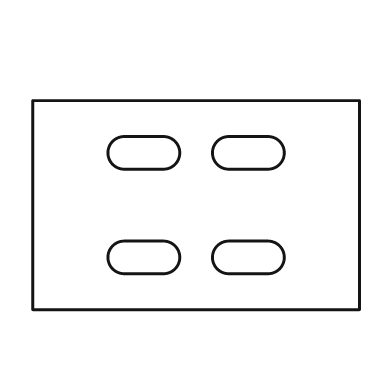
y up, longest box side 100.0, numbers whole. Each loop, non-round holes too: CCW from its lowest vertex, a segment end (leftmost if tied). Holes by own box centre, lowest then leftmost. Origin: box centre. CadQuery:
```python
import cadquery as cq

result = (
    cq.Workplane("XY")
    .moveTo(-50.0, -32.0)
    .lineTo(50.0, -32.0)
    .lineTo(50.0, 32.0)
    .lineTo(-50.0, 32.0)
    .close()
    .moveTo(-22.0, -21.0)
    .lineTo(-10.0, -21.0)
    .threePointArc((-5.0, -16.0), (-10.0, -11.0))
    .lineTo(-22.0, -11.0)
    .threePointArc((-27.0, -16.0), (-22.0, -21.0))
    .close()
    .moveTo(10.0, -21.0)
    .lineTo(22.0, -21.0)
    .threePointArc((27.0, -16.0), (22.0, -11.0))
    .lineTo(10.0, -11.0)
    .threePointArc((5.0, -16.0), (10.0, -21.0))
    .close()
    .moveTo(-22.0, 11.0)
    .lineTo(-10.0, 11.0)
    .threePointArc((-5.0, 16.0), (-10.0, 21.0))
    .lineTo(-22.0, 21.0)
    .threePointArc((-27.0, 16.0), (-22.0, 11.0))
    .close()
    .moveTo(10.0, 11.0)
    .lineTo(22.0, 11.0)
    .threePointArc((27.0, 16.0), (22.0, 21.0))
    .lineTo(10.0, 21.0)
    .threePointArc((5.0, 16.0), (10.0, 11.0))
    .close()
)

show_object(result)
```